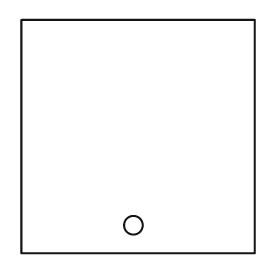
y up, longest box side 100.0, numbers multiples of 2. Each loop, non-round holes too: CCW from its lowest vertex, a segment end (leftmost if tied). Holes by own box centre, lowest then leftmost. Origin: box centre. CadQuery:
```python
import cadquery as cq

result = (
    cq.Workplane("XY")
    .moveTo(-50.0, -50.0)
    .lineTo(50.0, -50.0)
    .lineTo(50.0, 50.0)
    .lineTo(-50.0, 50.0)
    .close()
    .moveTo(-2.0, -38.0)
    .circle(4.0)
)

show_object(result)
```